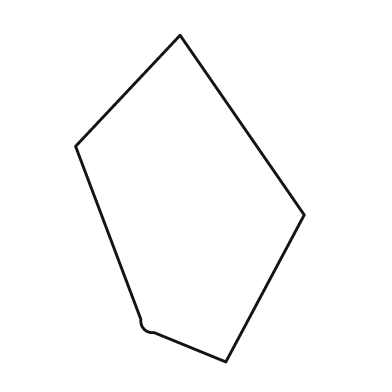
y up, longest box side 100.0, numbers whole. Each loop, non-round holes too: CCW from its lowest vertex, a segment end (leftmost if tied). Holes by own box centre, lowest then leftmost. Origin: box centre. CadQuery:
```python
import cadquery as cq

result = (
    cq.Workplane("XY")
    .moveTo(11.0, -50.0)
    .lineTo(35.0, -5.0)
    .lineTo(-3.0, 50.0)
    .lineTo(-35.0, 16.0)
    .lineTo(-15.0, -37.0)
    .threePointArc((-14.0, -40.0), (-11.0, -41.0))
    .close()
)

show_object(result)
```